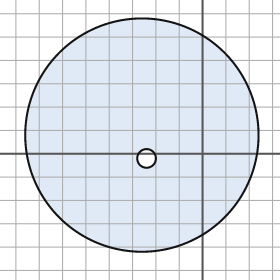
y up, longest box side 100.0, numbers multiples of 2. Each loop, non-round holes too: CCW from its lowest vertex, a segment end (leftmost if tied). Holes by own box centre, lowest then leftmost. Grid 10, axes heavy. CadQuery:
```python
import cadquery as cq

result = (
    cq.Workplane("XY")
    .moveTo(-26.0, 8.0)
    .circle(50.0)
    .moveTo(-24.0, -2.0)
    .circle(4.0)
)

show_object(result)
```